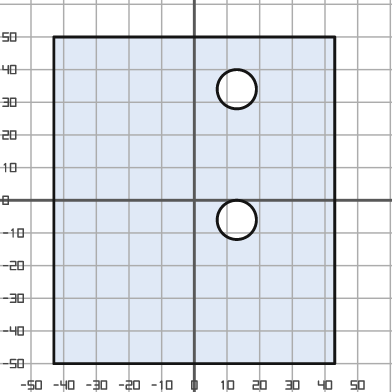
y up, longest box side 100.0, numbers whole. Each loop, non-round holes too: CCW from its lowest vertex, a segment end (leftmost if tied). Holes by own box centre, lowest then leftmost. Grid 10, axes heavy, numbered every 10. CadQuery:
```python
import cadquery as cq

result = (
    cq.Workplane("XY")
    .moveTo(-43.0, -50.0)
    .lineTo(43.0, -50.0)
    .lineTo(43.0, 50.0)
    .lineTo(-43.0, 50.0)
    .close()
    .moveTo(13.0, -6.0)
    .circle(6.0)
    .moveTo(13.0, 34.0)
    .circle(6.0)
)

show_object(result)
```